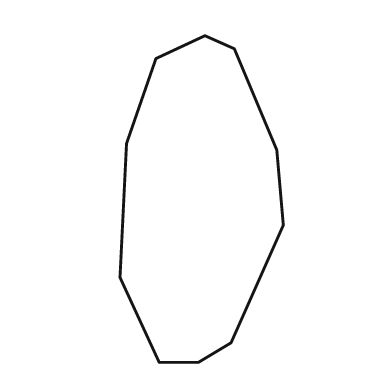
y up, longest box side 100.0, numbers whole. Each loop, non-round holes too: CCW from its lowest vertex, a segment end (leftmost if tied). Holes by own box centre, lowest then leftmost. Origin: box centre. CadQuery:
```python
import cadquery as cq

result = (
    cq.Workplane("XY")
    .moveTo(-13.0, -50.0)
    .lineTo(-1.0, -50.0)
    .lineTo(9.0, -44.0)
    .lineTo(25.0, -8.0)
    .lineTo(23.0, 15.0)
    .lineTo(10.0, 46.0)
    .lineTo(1.0, 50.0)
    .lineTo(-14.0, 43.0)
    .lineTo(-23.0, 17.0)
    .lineTo(-25.0, -24.0)
    .close()
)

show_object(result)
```